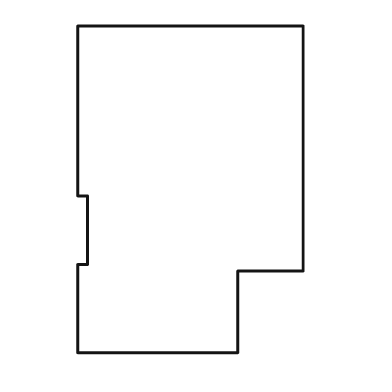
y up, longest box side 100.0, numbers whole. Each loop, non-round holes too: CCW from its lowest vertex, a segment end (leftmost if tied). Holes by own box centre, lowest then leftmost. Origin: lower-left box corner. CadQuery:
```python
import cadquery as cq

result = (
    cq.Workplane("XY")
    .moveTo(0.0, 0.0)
    .lineTo(49.0, 0.0)
    .lineTo(49.0, 25.0)
    .lineTo(69.0, 25.0)
    .lineTo(69.0, 100.0)
    .lineTo(0.0, 100.0)
    .lineTo(0.0, 48.0)
    .lineTo(3.0, 48.0)
    .lineTo(3.0, 27.0)
    .lineTo(0.0, 27.0)
    .close()
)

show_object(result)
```